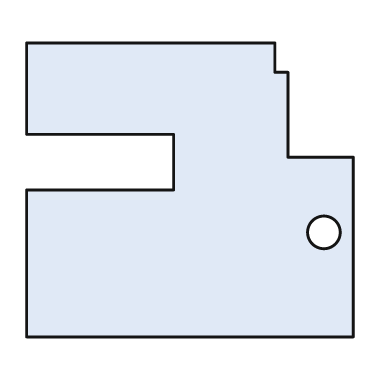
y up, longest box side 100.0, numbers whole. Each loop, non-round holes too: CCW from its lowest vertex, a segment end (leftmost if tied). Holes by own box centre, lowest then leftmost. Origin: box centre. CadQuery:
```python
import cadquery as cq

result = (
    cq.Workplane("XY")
    .moveTo(-50.0, -45.0)
    .lineTo(50.0, -45.0)
    .lineTo(50.0, 10.0)
    .lineTo(30.0, 10.0)
    .lineTo(30.0, 36.0)
    .lineTo(26.0, 36.0)
    .lineTo(26.0, 45.0)
    .lineTo(-50.0, 45.0)
    .lineTo(-50.0, 17.0)
    .lineTo(-5.0, 17.0)
    .lineTo(-5.0, 0.0)
    .lineTo(-50.0, 0.0)
    .close()
    .moveTo(41.0, -13.0)
    .circle(5.0)
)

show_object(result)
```